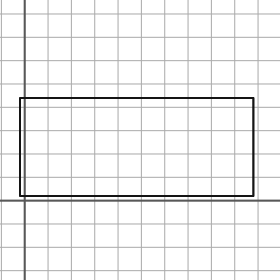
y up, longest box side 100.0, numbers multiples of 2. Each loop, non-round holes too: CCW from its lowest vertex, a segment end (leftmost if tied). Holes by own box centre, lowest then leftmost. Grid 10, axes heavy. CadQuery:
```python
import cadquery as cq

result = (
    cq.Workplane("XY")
    .moveTo(-2.0, 2.0)
    .lineTo(98.0, 2.0)
    .lineTo(98.0, 44.0)
    .lineTo(-2.0, 44.0)
    .close()
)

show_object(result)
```